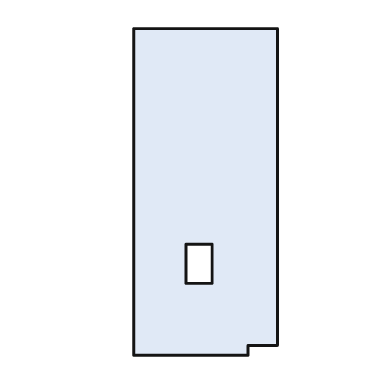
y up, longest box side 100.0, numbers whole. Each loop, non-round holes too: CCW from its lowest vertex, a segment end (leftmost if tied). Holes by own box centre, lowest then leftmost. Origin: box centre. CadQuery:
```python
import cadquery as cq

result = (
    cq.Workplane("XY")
    .moveTo(-22.0, -50.0)
    .lineTo(13.0, -50.0)
    .lineTo(13.0, -47.0)
    .lineTo(22.0, -47.0)
    .lineTo(22.0, 50.0)
    .lineTo(-22.0, 50.0)
    .close()
    .moveTo(-6.0, -28.0)
    .lineTo(2.0, -28.0)
    .lineTo(2.0, -16.0)
    .lineTo(-6.0, -16.0)
    .close()
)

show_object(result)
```